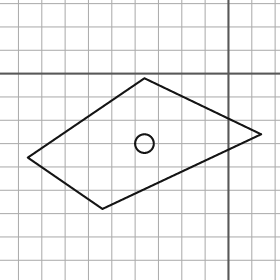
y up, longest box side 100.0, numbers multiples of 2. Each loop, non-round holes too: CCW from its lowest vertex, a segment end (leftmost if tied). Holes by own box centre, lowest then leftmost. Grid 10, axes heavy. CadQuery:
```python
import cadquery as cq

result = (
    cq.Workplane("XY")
    .moveTo(-54.0, -58.0)
    .lineTo(14.0, -26.0)
    .lineTo(-36.0, -2.0)
    .lineTo(-86.0, -36.0)
    .close()
    .moveTo(-36.0, -30.0)
    .circle(4.0)
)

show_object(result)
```